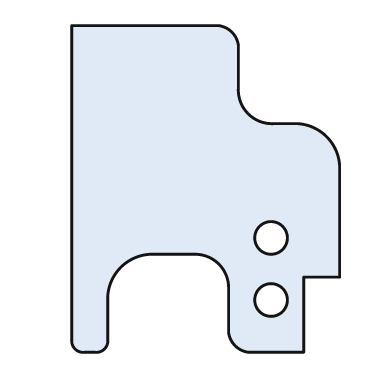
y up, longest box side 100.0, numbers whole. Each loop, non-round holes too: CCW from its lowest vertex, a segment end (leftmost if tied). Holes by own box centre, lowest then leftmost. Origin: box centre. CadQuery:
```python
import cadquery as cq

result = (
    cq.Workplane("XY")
    .moveTo(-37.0, -50.0)
    .lineTo(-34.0, -50.0)
    .threePointArc((-31.0, -49.0), (-30.0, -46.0))
    .lineTo(-30.0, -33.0)
    .threePointArc((-26.0, -24.0), (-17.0, -20.0))
    .lineTo(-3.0, -20.0)
    .threePointArc((4.0, -23.0), (7.0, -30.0))
    .lineTo(7.0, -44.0)
    .threePointArc((9.0, -48.0), (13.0, -50.0))
    .lineTo(30.0, -50.0)
    .lineTo(30.0, -27.0)
    .lineTo(41.0, -27.0)
    .lineTo(41.0, 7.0)
    .threePointArc((37.0, 16.0), (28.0, 20.0))
    .lineTo(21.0, 20.0)
    .threePointArc((13.0, 23.0), (10.0, 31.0))
    .lineTo(10.0, 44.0)
    .threePointArc((8.0, 48.0), (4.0, 50.0))
    .lineTo(-41.0, 50.0)
    .lineTo(-41.0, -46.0)
    .threePointArc((-40.0, -49.0), (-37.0, -50.0))
    .close()
    .moveTo(20.0, -34.0)
    .circle(5.0)
    .moveTo(20.0, -15.0)
    .circle(5.0)
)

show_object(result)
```